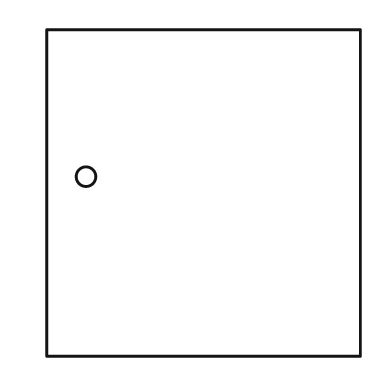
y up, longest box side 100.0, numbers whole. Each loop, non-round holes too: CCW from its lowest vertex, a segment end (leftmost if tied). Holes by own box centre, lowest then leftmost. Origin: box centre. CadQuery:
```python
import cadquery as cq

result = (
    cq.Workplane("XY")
    .moveTo(-48.0, -50.0)
    .lineTo(48.0, -50.0)
    .lineTo(48.0, 50.0)
    .lineTo(-48.0, 50.0)
    .close()
    .moveTo(-36.0, 5.0)
    .circle(3.0)
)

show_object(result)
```